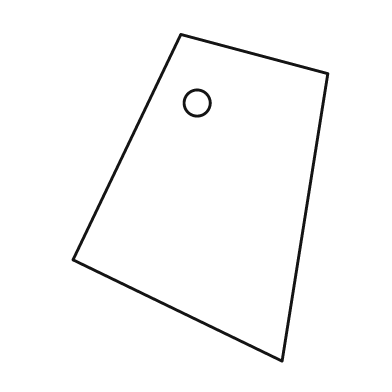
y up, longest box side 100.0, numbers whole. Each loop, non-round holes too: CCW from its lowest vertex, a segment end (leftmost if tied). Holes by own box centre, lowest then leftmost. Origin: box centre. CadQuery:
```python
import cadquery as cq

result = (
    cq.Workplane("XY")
    .moveTo(25.0, -50.0)
    .lineTo(39.0, 38.0)
    .lineTo(-6.0, 50.0)
    .lineTo(-39.0, -19.0)
    .close()
    .moveTo(-1.0, 29.0)
    .circle(4.0)
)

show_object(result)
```